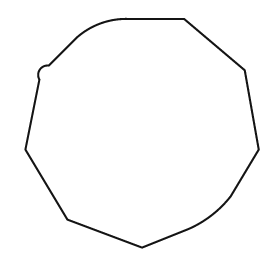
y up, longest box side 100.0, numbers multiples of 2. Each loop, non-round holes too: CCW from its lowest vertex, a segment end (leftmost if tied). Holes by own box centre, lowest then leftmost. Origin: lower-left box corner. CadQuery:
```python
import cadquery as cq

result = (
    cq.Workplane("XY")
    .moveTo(50.0, 0.0)
    .lineTo(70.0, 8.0)
    .threePointArc((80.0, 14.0), (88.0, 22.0))
    .lineTo(100.0, 42.0)
    .lineTo(94.0, 76.0)
    .lineTo(68.0, 98.0)
    .lineTo(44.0, 98.0)
    .threePointArc((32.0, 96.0), (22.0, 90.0))
    .lineTo(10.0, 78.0)
    .threePointArc((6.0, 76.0), (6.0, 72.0))
    .lineTo(0.0, 42.0)
    .lineTo(18.0, 12.0)
    .close()
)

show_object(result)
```